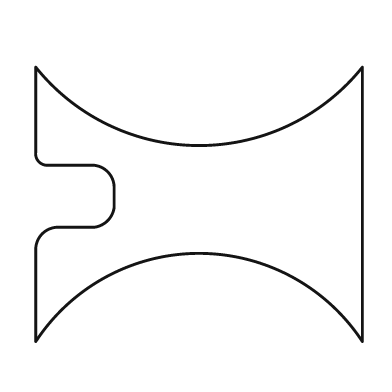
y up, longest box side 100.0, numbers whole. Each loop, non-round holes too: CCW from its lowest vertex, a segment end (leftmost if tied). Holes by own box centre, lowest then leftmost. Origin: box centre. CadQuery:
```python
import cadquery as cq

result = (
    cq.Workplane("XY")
    .moveTo(-50.0, -42.0)
    .threePointArc((0.0, -15.0), (50.0, -42.0))
    .lineTo(50.0, 42.0)
    .threePointArc((0.0, 18.0), (-50.0, 42.0))
    .lineTo(-50.0, 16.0)
    .threePointArc((-49.0, 13.0), (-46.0, 12.0))
    .lineTo(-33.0, 12.0)
    .threePointArc((-28.0, 10.0), (-26.0, 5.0))
    .lineTo(-26.0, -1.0)
    .threePointArc((-28.0, -5.0), (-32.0, -7.0))
    .lineTo(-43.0, -7.0)
    .threePointArc((-48.0, -9.0), (-50.0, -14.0))
    .close()
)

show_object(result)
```